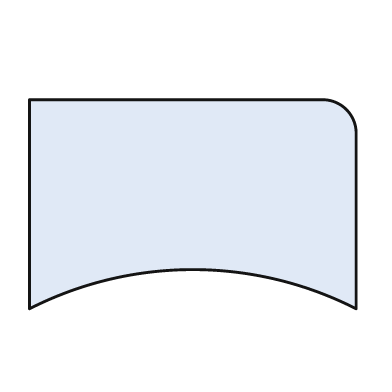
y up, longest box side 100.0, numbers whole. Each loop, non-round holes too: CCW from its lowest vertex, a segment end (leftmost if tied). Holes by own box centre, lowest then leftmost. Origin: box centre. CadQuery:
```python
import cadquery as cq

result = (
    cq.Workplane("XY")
    .moveTo(-50.0, -32.0)
    .threePointArc((0.0, -20.0), (50.0, -32.0))
    .lineTo(50.0, 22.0)
    .threePointArc((47.0, 29.0), (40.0, 32.0))
    .lineTo(-50.0, 32.0)
    .close()
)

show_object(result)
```